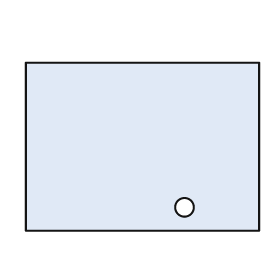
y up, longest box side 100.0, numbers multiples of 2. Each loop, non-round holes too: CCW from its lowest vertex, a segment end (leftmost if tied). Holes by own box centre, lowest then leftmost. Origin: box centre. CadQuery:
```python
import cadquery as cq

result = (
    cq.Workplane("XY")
    .moveTo(-50.0, -36.0)
    .lineTo(50.0, -36.0)
    .lineTo(50.0, 36.0)
    .lineTo(-50.0, 36.0)
    .close()
    .moveTo(18.0, -26.0)
    .circle(4.0)
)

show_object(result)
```